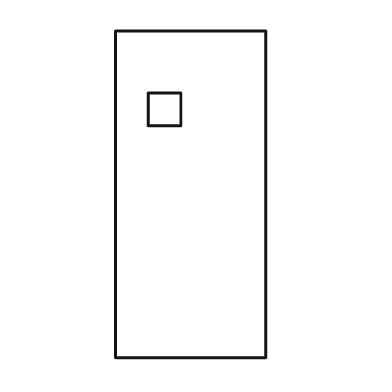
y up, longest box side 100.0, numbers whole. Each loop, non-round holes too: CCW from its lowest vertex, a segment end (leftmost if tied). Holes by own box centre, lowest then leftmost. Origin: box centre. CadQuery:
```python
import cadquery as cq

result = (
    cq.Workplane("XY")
    .moveTo(-23.0, -50.0)
    .lineTo(23.0, -50.0)
    .lineTo(23.0, 50.0)
    .lineTo(-23.0, 50.0)
    .close()
    .moveTo(-13.0, 21.0)
    .lineTo(-3.0, 21.0)
    .lineTo(-3.0, 31.0)
    .lineTo(-13.0, 31.0)
    .close()
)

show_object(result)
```